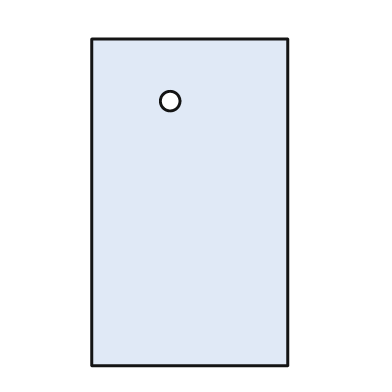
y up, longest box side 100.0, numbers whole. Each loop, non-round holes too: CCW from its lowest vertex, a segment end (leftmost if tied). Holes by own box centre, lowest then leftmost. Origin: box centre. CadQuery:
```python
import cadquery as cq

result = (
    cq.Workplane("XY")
    .moveTo(-30.0, -50.0)
    .lineTo(30.0, -50.0)
    .lineTo(30.0, 50.0)
    .lineTo(-30.0, 50.0)
    .close()
    .moveTo(-6.0, 31.0)
    .circle(3.0)
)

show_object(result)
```